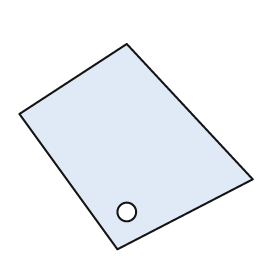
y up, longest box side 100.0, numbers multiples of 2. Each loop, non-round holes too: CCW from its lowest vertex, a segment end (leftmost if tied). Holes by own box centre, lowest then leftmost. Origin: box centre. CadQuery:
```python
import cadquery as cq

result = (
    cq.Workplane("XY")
    .moveTo(-8.0, -44.0)
    .lineTo(50.0, -14.0)
    .lineTo(-4.0, 44.0)
    .lineTo(-50.0, 14.0)
    .close()
    .moveTo(-4.0, -28.0)
    .circle(4.0)
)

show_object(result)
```